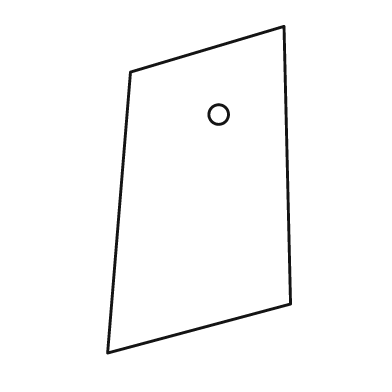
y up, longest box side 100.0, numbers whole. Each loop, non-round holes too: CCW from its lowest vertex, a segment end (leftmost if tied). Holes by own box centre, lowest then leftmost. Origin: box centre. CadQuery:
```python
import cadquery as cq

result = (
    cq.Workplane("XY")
    .moveTo(-28.0, -50.0)
    .lineTo(28.0, -35.0)
    .lineTo(26.0, 50.0)
    .lineTo(-21.0, 36.0)
    .close()
    .moveTo(6.0, 23.0)
    .circle(3.0)
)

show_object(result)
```